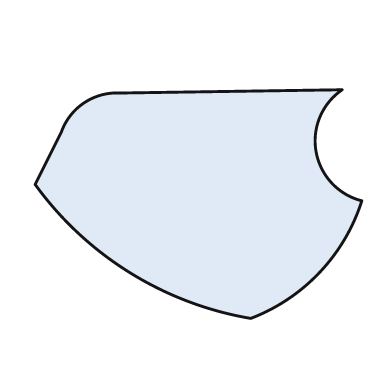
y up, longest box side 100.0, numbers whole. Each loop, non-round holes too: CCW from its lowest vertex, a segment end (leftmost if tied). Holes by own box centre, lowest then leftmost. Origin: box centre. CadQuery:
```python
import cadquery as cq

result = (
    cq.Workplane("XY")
    .moveTo(16.0, -35.0)
    .threePointArc((37.0, -21.0), (50.0, 1.0))
    .threePointArc((36.0, 16.0), (44.0, 35.0))
    .lineTo(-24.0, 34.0)
    .threePointArc((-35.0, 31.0), (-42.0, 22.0))
    .lineTo(-50.0, 6.0)
    .threePointArc((-21.0, -21.0), (16.0, -35.0))
    .close()
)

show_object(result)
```